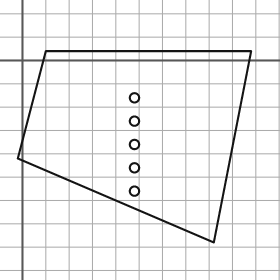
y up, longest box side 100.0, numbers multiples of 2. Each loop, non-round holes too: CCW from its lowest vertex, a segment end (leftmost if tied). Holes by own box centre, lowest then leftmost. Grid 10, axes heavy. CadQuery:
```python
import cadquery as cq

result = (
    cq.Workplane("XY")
    .moveTo(82.0, -78.0)
    .lineTo(98.0, 4.0)
    .lineTo(10.0, 4.0)
    .lineTo(-2.0, -42.0)
    .close()
    .moveTo(48.0, -56.0)
    .circle(2.0)
    .moveTo(48.0, -46.0)
    .circle(2.0)
    .moveTo(48.0, -36.0)
    .circle(2.0)
    .moveTo(48.0, -26.0)
    .circle(2.0)
    .moveTo(48.0, -16.0)
    .circle(2.0)
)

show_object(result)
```